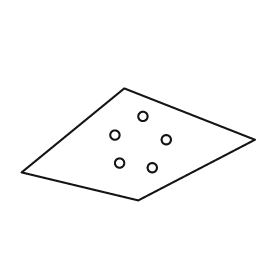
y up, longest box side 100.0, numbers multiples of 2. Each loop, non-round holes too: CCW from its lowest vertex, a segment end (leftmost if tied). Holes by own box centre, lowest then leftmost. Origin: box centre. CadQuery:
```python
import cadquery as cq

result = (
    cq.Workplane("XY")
    .moveTo(0.0, -24.0)
    .lineTo(50.0, 2.0)
    .lineTo(-6.0, 24.0)
    .lineTo(-50.0, -12.0)
    .close()
    .moveTo(6.0, -10.0)
    .circle(2.0)
    .moveTo(-8.0, -8.0)
    .circle(2.0)
    .moveTo(12.0, 2.0)
    .circle(2.0)
    .moveTo(-10.0, 4.0)
    .circle(2.0)
    .moveTo(2.0, 12.0)
    .circle(2.0)
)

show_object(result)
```